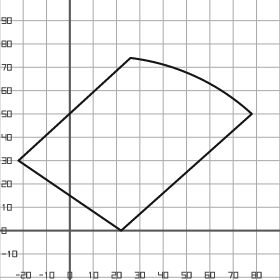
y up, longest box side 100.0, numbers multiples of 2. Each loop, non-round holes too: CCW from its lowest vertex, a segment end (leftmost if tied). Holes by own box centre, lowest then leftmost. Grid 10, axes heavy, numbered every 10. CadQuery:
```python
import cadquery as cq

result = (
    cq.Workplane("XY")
    .moveTo(22.0, 0.0)
    .lineTo(78.0, 50.0)
    .threePointArc((54.0, 66.0), (26.0, 74.0))
    .lineTo(-22.0, 30.0)
    .close()
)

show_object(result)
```